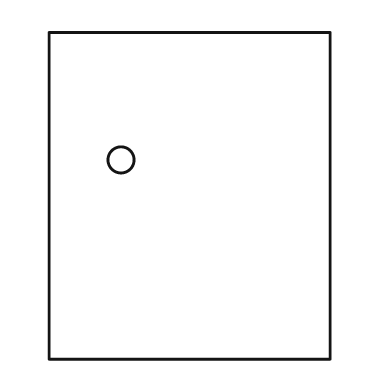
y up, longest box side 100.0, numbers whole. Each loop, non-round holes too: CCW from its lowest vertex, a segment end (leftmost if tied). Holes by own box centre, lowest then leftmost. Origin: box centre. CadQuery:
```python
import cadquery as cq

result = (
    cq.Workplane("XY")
    .moveTo(-43.0, -50.0)
    .lineTo(43.0, -50.0)
    .lineTo(43.0, 50.0)
    .lineTo(-43.0, 50.0)
    .close()
    .moveTo(-21.0, 11.0)
    .circle(4.0)
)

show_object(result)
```